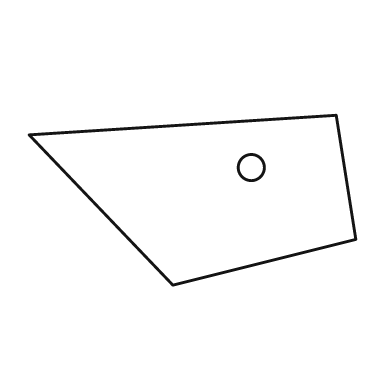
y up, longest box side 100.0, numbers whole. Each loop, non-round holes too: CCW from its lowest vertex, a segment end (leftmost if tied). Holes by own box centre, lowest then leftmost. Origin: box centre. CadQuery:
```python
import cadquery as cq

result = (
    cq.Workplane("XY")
    .moveTo(-6.0, -26.0)
    .lineTo(50.0, -12.0)
    .lineTo(44.0, 26.0)
    .lineTo(-50.0, 20.0)
    .close()
    .moveTo(18.0, 10.0)
    .circle(4.0)
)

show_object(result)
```